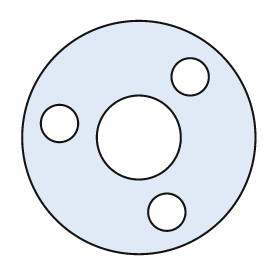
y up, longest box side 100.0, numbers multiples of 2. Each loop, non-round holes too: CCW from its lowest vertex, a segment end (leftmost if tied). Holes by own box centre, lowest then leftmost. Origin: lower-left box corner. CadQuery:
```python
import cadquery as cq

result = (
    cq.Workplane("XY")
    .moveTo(50.0, 50.0)
    .circle(50.0)
    .moveTo(62.0, 18.0)
    .circle(8.0)
    .moveTo(50.0, 50.0)
    .circle(18.0)
    .moveTo(16.0, 56.0)
    .circle(8.0)
    .moveTo(72.0, 76.0)
    .circle(8.0)
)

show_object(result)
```